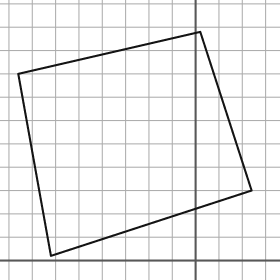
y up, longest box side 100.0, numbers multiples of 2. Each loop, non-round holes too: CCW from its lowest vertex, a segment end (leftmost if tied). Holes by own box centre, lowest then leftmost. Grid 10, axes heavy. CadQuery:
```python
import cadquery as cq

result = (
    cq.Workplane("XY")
    .moveTo(-62.0, 2.0)
    .lineTo(24.0, 30.0)
    .lineTo(2.0, 98.0)
    .lineTo(-76.0, 80.0)
    .close()
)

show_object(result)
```